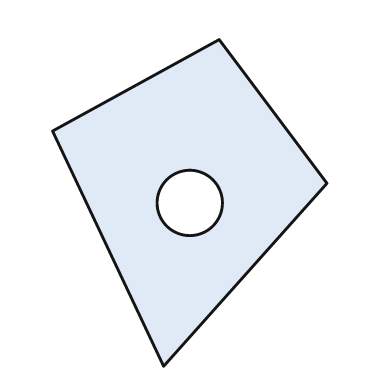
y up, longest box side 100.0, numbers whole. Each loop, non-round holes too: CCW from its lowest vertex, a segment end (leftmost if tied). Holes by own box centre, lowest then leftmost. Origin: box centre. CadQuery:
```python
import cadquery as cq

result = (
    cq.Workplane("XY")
    .moveTo(-8.0, -50.0)
    .lineTo(42.0, 6.0)
    .lineTo(9.0, 50.0)
    .lineTo(-42.0, 22.0)
    .close()
    .moveTo(0.0, 0.0)
    .circle(10.0)
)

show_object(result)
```